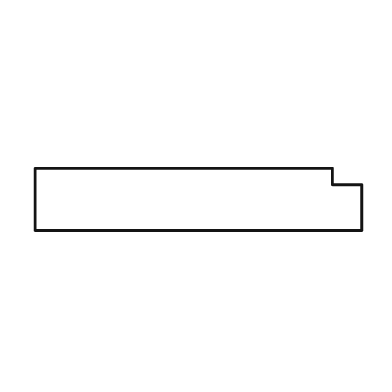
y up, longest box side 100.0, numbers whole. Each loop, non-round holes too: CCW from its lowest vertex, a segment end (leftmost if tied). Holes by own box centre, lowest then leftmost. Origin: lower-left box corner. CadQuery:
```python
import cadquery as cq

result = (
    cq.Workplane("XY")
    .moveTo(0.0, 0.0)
    .lineTo(100.0, 0.0)
    .lineTo(100.0, 14.0)
    .lineTo(91.0, 14.0)
    .lineTo(91.0, 19.0)
    .lineTo(0.0, 19.0)
    .close()
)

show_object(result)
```